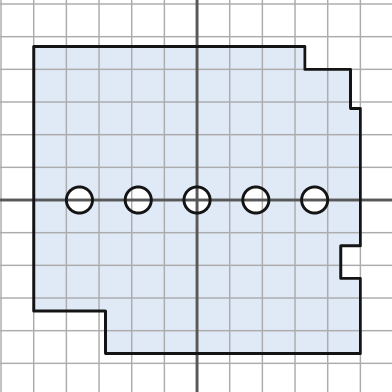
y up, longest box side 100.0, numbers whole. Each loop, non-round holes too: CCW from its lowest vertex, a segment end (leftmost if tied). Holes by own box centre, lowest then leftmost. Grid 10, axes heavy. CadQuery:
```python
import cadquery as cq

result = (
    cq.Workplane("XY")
    .moveTo(-28.0, -47.0)
    .lineTo(50.0, -47.0)
    .lineTo(50.0, -24.0)
    .lineTo(44.0, -24.0)
    .lineTo(44.0, -14.0)
    .lineTo(50.0, -14.0)
    .lineTo(50.0, 28.0)
    .lineTo(47.0, 28.0)
    .lineTo(47.0, 40.0)
    .lineTo(33.0, 40.0)
    .lineTo(33.0, 47.0)
    .lineTo(-50.0, 47.0)
    .lineTo(-50.0, -34.0)
    .lineTo(-28.0, -34.0)
    .close()
    .moveTo(-36.0, 0.0)
    .circle(4.0)
    .moveTo(-18.0, 0.0)
    .circle(4.0)
    .moveTo(0.0, 0.0)
    .circle(4.0)
    .moveTo(18.0, 0.0)
    .circle(4.0)
    .moveTo(36.0, 0.0)
    .circle(4.0)
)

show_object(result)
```